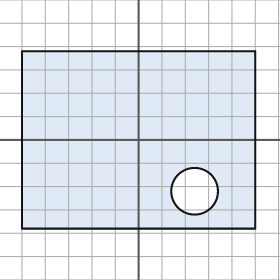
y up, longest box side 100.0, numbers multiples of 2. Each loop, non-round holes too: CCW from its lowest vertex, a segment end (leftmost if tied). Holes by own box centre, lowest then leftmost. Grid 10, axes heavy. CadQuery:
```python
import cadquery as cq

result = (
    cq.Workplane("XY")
    .moveTo(-50.0, -38.0)
    .lineTo(50.0, -38.0)
    .lineTo(50.0, 38.0)
    .lineTo(-50.0, 38.0)
    .close()
    .moveTo(24.0, -22.0)
    .circle(10.0)
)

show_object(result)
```